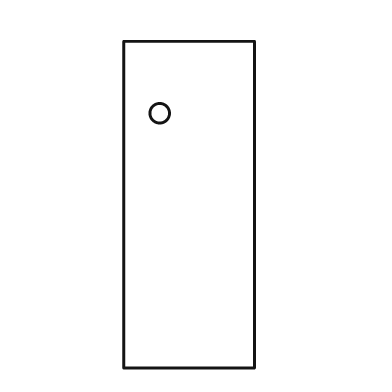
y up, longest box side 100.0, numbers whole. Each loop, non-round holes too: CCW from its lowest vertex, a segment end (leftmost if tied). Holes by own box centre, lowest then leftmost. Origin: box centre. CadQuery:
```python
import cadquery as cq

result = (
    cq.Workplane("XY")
    .moveTo(-20.0, -50.0)
    .lineTo(20.0, -50.0)
    .lineTo(20.0, 50.0)
    .lineTo(-20.0, 50.0)
    .close()
    .moveTo(-9.0, 28.0)
    .circle(3.0)
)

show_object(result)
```